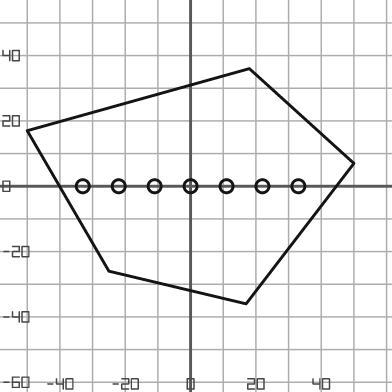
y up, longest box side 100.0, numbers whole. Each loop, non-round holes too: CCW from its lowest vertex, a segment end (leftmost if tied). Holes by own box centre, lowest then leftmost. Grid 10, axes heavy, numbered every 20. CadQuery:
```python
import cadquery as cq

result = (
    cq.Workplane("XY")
    .moveTo(17.0, -36.0)
    .lineTo(50.0, 7.0)
    .lineTo(18.0, 36.0)
    .lineTo(-50.0, 17.0)
    .lineTo(-25.0, -26.0)
    .close()
    .moveTo(-33.0, 0.0)
    .circle(2.0)
    .moveTo(-22.0, 0.0)
    .circle(2.0)
    .moveTo(-11.0, 0.0)
    .circle(2.0)
    .moveTo(0.0, 0.0)
    .circle(2.0)
    .moveTo(11.0, 0.0)
    .circle(2.0)
    .moveTo(22.0, 0.0)
    .circle(2.0)
    .moveTo(33.0, 0.0)
    .circle(2.0)
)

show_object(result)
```